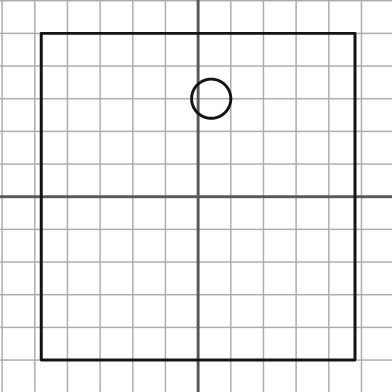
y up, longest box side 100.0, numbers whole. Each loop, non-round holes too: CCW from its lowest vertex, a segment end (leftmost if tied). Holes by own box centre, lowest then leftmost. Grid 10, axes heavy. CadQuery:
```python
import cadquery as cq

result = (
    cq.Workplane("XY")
    .moveTo(-48.0, -50.0)
    .lineTo(48.0, -50.0)
    .lineTo(48.0, 50.0)
    .lineTo(-48.0, 50.0)
    .close()
    .moveTo(4.0, 30.0)
    .circle(6.0)
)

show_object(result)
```